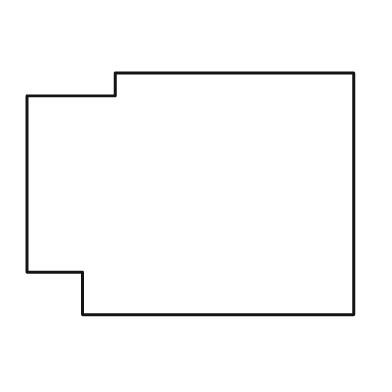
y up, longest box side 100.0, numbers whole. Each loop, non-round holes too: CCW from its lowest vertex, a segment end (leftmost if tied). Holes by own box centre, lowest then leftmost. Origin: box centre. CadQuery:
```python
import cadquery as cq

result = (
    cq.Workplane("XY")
    .moveTo(-33.0, -37.0)
    .lineTo(50.0, -37.0)
    .lineTo(50.0, 37.0)
    .lineTo(-23.0, 37.0)
    .lineTo(-23.0, 30.0)
    .lineTo(-50.0, 30.0)
    .lineTo(-50.0, -24.0)
    .lineTo(-33.0, -24.0)
    .close()
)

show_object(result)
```